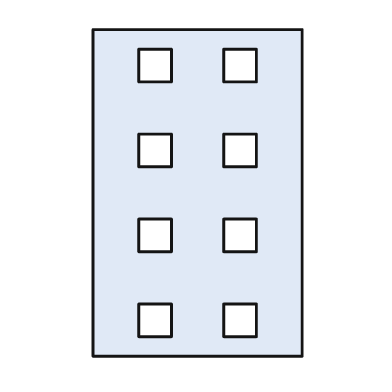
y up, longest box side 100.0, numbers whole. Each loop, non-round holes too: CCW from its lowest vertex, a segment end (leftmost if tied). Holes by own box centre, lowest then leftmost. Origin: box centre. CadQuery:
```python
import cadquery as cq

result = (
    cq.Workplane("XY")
    .moveTo(-32.0, -50.0)
    .lineTo(32.0, -50.0)
    .lineTo(32.0, 50.0)
    .lineTo(-32.0, 50.0)
    .close()
    .moveTo(-18.0, -44.0)
    .lineTo(-8.0, -44.0)
    .lineTo(-8.0, -34.0)
    .lineTo(-18.0, -34.0)
    .close()
    .moveTo(8.0, -44.0)
    .lineTo(18.0, -44.0)
    .lineTo(18.0, -34.0)
    .lineTo(8.0, -34.0)
    .close()
    .moveTo(-18.0, -18.0)
    .lineTo(-8.0, -18.0)
    .lineTo(-8.0, -8.0)
    .lineTo(-18.0, -8.0)
    .close()
    .moveTo(8.0, -18.0)
    .lineTo(18.0, -18.0)
    .lineTo(18.0, -8.0)
    .lineTo(8.0, -8.0)
    .close()
    .moveTo(-18.0, 8.0)
    .lineTo(-8.0, 8.0)
    .lineTo(-8.0, 18.0)
    .lineTo(-18.0, 18.0)
    .close()
    .moveTo(8.0, 8.0)
    .lineTo(18.0, 8.0)
    .lineTo(18.0, 18.0)
    .lineTo(8.0, 18.0)
    .close()
    .moveTo(-18.0, 34.0)
    .lineTo(-8.0, 34.0)
    .lineTo(-8.0, 44.0)
    .lineTo(-18.0, 44.0)
    .close()
    .moveTo(8.0, 34.0)
    .lineTo(18.0, 34.0)
    .lineTo(18.0, 44.0)
    .lineTo(8.0, 44.0)
    .close()
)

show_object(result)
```